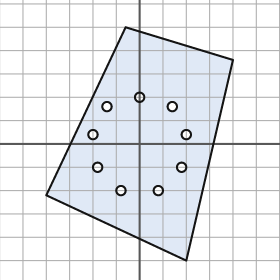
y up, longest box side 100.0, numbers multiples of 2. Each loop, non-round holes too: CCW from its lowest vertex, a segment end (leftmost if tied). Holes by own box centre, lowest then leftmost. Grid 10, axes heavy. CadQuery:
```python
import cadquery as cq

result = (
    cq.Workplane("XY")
    .moveTo(20.0, -50.0)
    .lineTo(40.0, 36.0)
    .lineTo(-6.0, 50.0)
    .lineTo(-40.0, -22.0)
    .close()
    .moveTo(-8.0, -20.0)
    .circle(2.0)
    .moveTo(8.0, -20.0)
    .circle(2.0)
    .moveTo(-18.0, -10.0)
    .circle(2.0)
    .moveTo(18.0, -10.0)
    .circle(2.0)
    .moveTo(-20.0, 4.0)
    .circle(2.0)
    .moveTo(20.0, 4.0)
    .circle(2.0)
    .moveTo(-14.0, 16.0)
    .circle(2.0)
    .moveTo(14.0, 16.0)
    .circle(2.0)
    .moveTo(0.0, 20.0)
    .circle(2.0)
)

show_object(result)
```